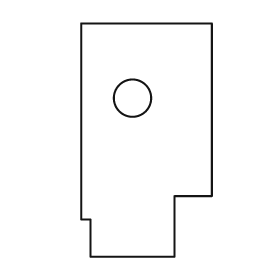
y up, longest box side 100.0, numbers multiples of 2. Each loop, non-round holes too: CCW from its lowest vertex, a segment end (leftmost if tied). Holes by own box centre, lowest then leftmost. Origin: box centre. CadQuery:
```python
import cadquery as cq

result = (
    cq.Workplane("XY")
    .moveTo(-24.0, -50.0)
    .lineTo(12.0, -50.0)
    .lineTo(12.0, -24.0)
    .lineTo(28.0, -24.0)
    .lineTo(28.0, 50.0)
    .lineTo(-28.0, 50.0)
    .lineTo(-28.0, -34.0)
    .lineTo(-24.0, -34.0)
    .close()
    .moveTo(-6.0, 18.0)
    .circle(8.0)
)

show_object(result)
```